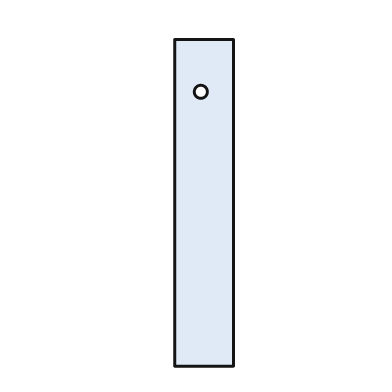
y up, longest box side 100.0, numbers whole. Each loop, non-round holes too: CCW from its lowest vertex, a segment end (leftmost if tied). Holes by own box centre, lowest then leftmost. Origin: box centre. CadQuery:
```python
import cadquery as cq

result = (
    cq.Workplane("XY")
    .moveTo(-9.0, -50.0)
    .lineTo(9.0, -50.0)
    .lineTo(9.0, 50.0)
    .lineTo(-9.0, 50.0)
    .close()
    .moveTo(-1.0, 34.0)
    .circle(2.0)
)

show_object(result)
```